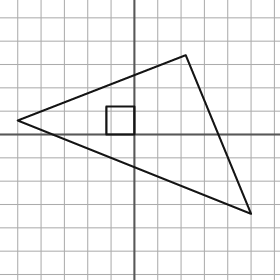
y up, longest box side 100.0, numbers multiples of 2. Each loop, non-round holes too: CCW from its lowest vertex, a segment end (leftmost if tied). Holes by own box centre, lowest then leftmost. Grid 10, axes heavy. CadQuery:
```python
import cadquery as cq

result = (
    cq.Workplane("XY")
    .moveTo(50.0, -34.0)
    .lineTo(22.0, 34.0)
    .lineTo(-50.0, 6.0)
    .close()
    .moveTo(-12.0, 0.0)
    .lineTo(0.0, 0.0)
    .lineTo(0.0, 12.0)
    .lineTo(-12.0, 12.0)
    .close()
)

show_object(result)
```